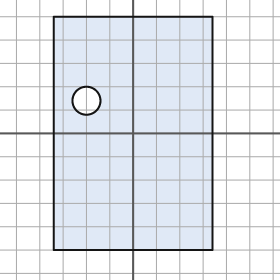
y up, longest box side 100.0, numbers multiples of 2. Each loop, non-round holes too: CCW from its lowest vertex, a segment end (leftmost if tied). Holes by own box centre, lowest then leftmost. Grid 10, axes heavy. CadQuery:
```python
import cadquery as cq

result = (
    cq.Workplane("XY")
    .moveTo(-34.0, -50.0)
    .lineTo(34.0, -50.0)
    .lineTo(34.0, 50.0)
    .lineTo(-34.0, 50.0)
    .close()
    .moveTo(-20.0, 14.0)
    .circle(6.0)
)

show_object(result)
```